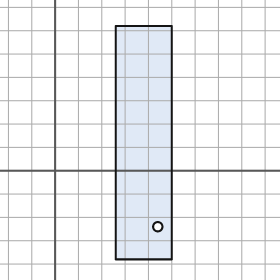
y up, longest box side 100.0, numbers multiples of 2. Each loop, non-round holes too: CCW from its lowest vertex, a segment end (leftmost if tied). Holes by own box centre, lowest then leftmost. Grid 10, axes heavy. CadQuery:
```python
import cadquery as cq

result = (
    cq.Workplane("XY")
    .moveTo(26.0, -38.0)
    .lineTo(50.0, -38.0)
    .lineTo(50.0, 62.0)
    .lineTo(26.0, 62.0)
    .close()
    .moveTo(44.0, -24.0)
    .circle(2.0)
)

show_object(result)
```